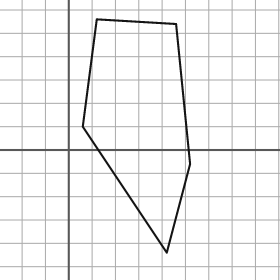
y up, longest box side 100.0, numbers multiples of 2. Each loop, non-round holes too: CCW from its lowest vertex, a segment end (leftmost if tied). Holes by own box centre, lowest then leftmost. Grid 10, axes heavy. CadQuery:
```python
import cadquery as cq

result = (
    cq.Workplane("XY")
    .moveTo(42.0, -44.0)
    .lineTo(52.0, -6.0)
    .lineTo(46.0, 54.0)
    .lineTo(12.0, 56.0)
    .lineTo(6.0, 10.0)
    .close()
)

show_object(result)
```